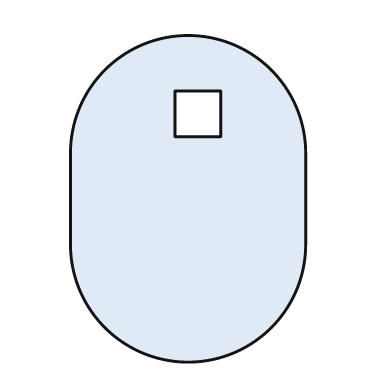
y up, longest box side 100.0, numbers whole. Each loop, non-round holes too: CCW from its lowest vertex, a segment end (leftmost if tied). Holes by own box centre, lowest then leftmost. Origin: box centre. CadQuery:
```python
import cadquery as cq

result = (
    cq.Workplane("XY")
    .moveTo(-36.0, -14.0)
    .threePointArc((0.0, -50.0), (36.0, -14.0))
    .lineTo(36.0, 14.0)
    .threePointArc((0.0, 50.0), (-36.0, 14.0))
    .close()
    .moveTo(-4.0, 19.0)
    .lineTo(10.0, 19.0)
    .lineTo(10.0, 33.0)
    .lineTo(-4.0, 33.0)
    .close()
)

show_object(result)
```